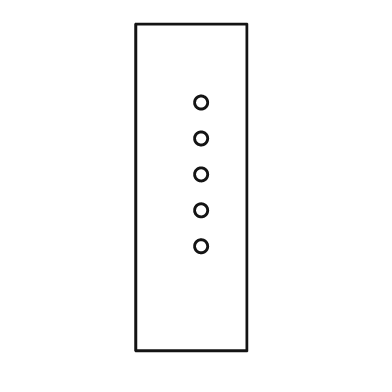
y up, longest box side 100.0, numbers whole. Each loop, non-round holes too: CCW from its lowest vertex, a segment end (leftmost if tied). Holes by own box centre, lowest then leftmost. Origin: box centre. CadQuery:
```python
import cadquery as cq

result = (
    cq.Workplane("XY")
    .moveTo(-17.0, -50.0)
    .lineTo(17.0, -50.0)
    .lineTo(17.0, 50.0)
    .lineTo(-17.0, 50.0)
    .close()
    .moveTo(3.0, -18.0)
    .circle(2.0)
    .moveTo(3.0, -7.0)
    .circle(2.0)
    .moveTo(3.0, 4.0)
    .circle(2.0)
    .moveTo(3.0, 15.0)
    .circle(2.0)
    .moveTo(3.0, 26.0)
    .circle(2.0)
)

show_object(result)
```